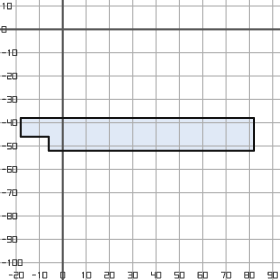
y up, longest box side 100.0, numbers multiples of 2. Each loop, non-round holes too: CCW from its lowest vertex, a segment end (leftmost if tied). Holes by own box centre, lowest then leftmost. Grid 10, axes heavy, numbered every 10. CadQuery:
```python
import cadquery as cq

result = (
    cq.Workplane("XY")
    .moveTo(-6.0, -52.0)
    .lineTo(82.0, -52.0)
    .lineTo(82.0, -38.0)
    .lineTo(-18.0, -38.0)
    .lineTo(-18.0, -46.0)
    .lineTo(-6.0, -46.0)
    .close()
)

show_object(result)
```